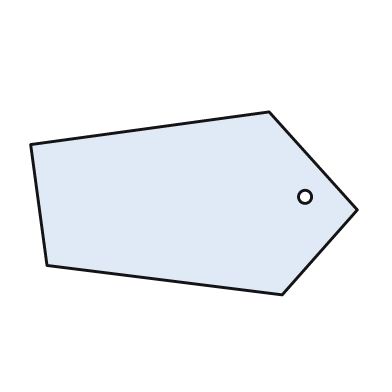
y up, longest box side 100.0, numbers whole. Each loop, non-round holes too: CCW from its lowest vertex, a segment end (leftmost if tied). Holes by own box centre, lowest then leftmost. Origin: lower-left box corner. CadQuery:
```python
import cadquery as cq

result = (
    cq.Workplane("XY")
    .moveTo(77.0, 0.0)
    .lineTo(100.0, 26.0)
    .lineTo(73.0, 56.0)
    .lineTo(0.0, 46.0)
    .lineTo(5.0, 9.0)
    .close()
    .moveTo(84.0, 30.0)
    .circle(2.0)
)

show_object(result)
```